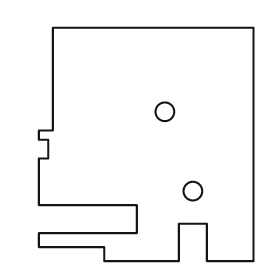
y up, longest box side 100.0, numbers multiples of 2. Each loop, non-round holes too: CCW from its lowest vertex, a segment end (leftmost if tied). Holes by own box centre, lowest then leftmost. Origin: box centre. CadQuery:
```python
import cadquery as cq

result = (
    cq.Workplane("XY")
    .moveTo(-18.0, -50.0)
    .lineTo(14.0, -50.0)
    .lineTo(14.0, -34.0)
    .lineTo(26.0, -34.0)
    .lineTo(26.0, -50.0)
    .lineTo(46.0, -50.0)
    .lineTo(46.0, 50.0)
    .lineTo(-40.0, 50.0)
    .lineTo(-40.0, 6.0)
    .lineTo(-46.0, 6.0)
    .lineTo(-46.0, 2.0)
    .lineTo(-42.0, 2.0)
    .lineTo(-42.0, -6.0)
    .lineTo(-46.0, -6.0)
    .lineTo(-46.0, -26.0)
    .lineTo(-4.0, -26.0)
    .lineTo(-4.0, -38.0)
    .lineTo(-46.0, -38.0)
    .lineTo(-46.0, -44.0)
    .lineTo(-18.0, -44.0)
    .close()
    .moveTo(20.0, -20.0)
    .circle(4.0)
    .moveTo(8.0, 14.0)
    .circle(4.0)
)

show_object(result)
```